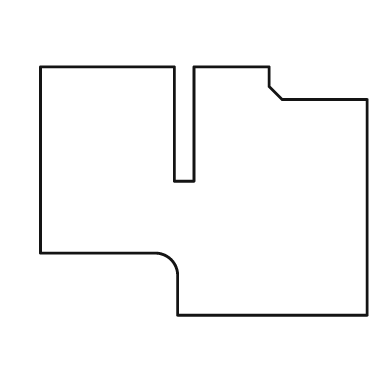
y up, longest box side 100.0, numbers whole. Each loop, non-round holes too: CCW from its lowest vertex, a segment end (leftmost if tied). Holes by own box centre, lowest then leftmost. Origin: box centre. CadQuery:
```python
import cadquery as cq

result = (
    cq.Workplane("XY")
    .moveTo(-8.0, -38.0)
    .lineTo(50.0, -38.0)
    .lineTo(50.0, 28.0)
    .lineTo(24.0, 28.0)
    .lineTo(20.0, 32.0)
    .lineTo(20.0, 38.0)
    .lineTo(-3.0, 38.0)
    .lineTo(-3.0, 3.0)
    .lineTo(-9.0, 3.0)
    .lineTo(-9.0, 38.0)
    .lineTo(-50.0, 38.0)
    .lineTo(-50.0, -19.0)
    .lineTo(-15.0, -19.0)
    .threePointArc((-10.0, -21.0), (-8.0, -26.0))
    .close()
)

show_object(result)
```